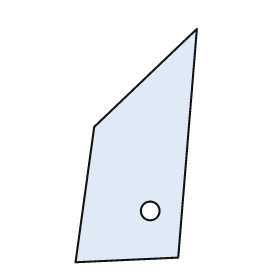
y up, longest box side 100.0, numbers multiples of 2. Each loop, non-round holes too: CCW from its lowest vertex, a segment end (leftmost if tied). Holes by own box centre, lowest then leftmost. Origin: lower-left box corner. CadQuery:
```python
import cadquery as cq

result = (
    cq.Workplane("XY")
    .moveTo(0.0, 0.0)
    .lineTo(44.0, 2.0)
    .lineTo(52.0, 100.0)
    .lineTo(8.0, 58.0)
    .close()
    .moveTo(32.0, 22.0)
    .circle(4.0)
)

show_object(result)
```